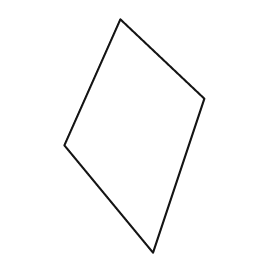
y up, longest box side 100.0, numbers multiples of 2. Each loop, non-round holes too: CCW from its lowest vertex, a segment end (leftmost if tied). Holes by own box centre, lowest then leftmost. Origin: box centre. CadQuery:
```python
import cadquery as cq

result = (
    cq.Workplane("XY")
    .moveTo(8.0, -50.0)
    .lineTo(30.0, 16.0)
    .lineTo(-6.0, 50.0)
    .lineTo(-30.0, -4.0)
    .close()
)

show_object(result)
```